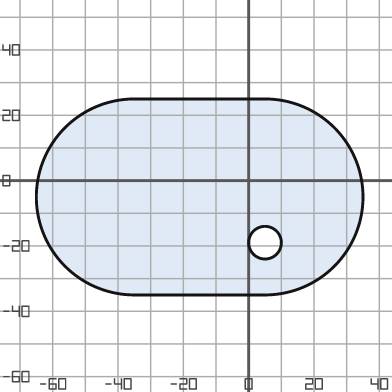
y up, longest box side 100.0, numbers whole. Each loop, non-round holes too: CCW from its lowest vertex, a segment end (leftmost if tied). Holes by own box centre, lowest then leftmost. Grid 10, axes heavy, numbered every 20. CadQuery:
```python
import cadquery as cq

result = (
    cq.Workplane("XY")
    .moveTo(-35.0, -35.0)
    .lineTo(5.0, -35.0)
    .threePointArc((35.0, -5.0), (5.0, 25.0))
    .lineTo(-35.0, 25.0)
    .threePointArc((-65.0, -5.0), (-35.0, -35.0))
    .close()
    .moveTo(5.0, -19.0)
    .circle(5.0)
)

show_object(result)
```